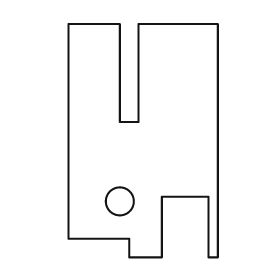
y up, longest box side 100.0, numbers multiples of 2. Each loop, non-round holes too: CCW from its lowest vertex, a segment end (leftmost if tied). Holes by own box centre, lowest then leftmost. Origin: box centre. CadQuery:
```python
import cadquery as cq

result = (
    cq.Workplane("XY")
    .moveTo(-6.0, -50.0)
    .lineTo(8.0, -50.0)
    .lineTo(8.0, -24.0)
    .lineTo(28.0, -24.0)
    .lineTo(28.0, -50.0)
    .lineTo(32.0, -50.0)
    .lineTo(32.0, 50.0)
    .lineTo(-2.0, 50.0)
    .lineTo(-2.0, 8.0)
    .lineTo(-10.0, 8.0)
    .lineTo(-10.0, 50.0)
    .lineTo(-32.0, 50.0)
    .lineTo(-32.0, -42.0)
    .lineTo(-6.0, -42.0)
    .close()
    .moveTo(-10.0, -26.0)
    .circle(6.0)
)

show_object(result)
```